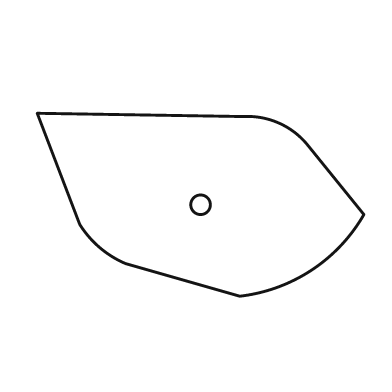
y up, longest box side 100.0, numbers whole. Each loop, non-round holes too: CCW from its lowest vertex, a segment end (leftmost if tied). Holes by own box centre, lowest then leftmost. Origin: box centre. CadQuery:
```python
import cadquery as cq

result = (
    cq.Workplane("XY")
    .moveTo(12.0, -28.0)
    .threePointArc((34.0, -20.0), (50.0, -3.0))
    .lineTo(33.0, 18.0)
    .threePointArc((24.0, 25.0), (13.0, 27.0))
    .lineTo(-50.0, 28.0)
    .lineTo(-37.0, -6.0)
    .threePointArc((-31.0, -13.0), (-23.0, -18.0))
    .close()
    .moveTo(0.0, 0.0)
    .circle(3.0)
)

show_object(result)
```